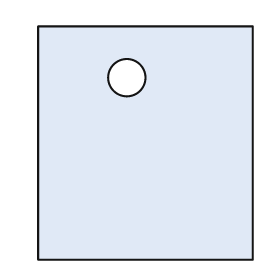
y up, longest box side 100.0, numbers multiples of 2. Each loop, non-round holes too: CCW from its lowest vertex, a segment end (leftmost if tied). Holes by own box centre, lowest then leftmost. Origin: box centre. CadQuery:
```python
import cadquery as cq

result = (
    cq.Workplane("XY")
    .moveTo(-46.0, -50.0)
    .lineTo(46.0, -50.0)
    .lineTo(46.0, 50.0)
    .lineTo(-46.0, 50.0)
    .close()
    .moveTo(-8.0, 28.0)
    .circle(8.0)
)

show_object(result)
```